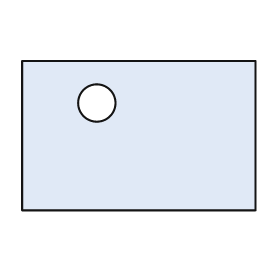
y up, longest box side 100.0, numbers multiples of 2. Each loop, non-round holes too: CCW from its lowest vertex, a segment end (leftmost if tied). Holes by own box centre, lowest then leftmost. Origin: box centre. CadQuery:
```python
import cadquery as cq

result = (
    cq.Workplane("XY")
    .moveTo(-50.0, -32.0)
    .lineTo(50.0, -32.0)
    .lineTo(50.0, 32.0)
    .lineTo(-50.0, 32.0)
    .close()
    .moveTo(-18.0, 14.0)
    .circle(8.0)
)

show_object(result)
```